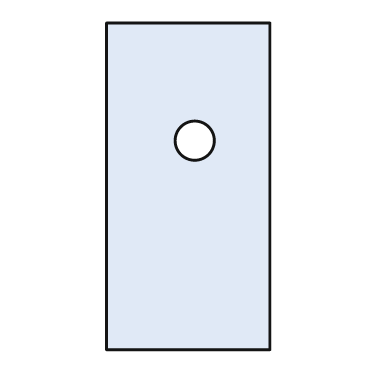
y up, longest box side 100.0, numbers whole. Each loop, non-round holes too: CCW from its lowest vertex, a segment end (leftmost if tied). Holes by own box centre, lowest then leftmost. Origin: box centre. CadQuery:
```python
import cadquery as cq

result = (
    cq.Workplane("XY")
    .moveTo(-25.0, -50.0)
    .lineTo(25.0, -50.0)
    .lineTo(25.0, 50.0)
    .lineTo(-25.0, 50.0)
    .close()
    .moveTo(2.0, 14.0)
    .circle(6.0)
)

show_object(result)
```